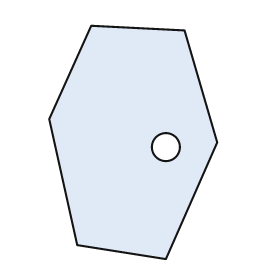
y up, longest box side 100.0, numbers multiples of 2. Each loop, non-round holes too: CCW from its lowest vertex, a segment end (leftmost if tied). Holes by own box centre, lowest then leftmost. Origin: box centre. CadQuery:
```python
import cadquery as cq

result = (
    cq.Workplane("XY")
    .moveTo(14.0, -50.0)
    .lineTo(36.0, 0.0)
    .lineTo(22.0, 48.0)
    .lineTo(-18.0, 50.0)
    .lineTo(-36.0, 10.0)
    .lineTo(-24.0, -44.0)
    .close()
    .moveTo(14.0, -2.0)
    .circle(6.0)
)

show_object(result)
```